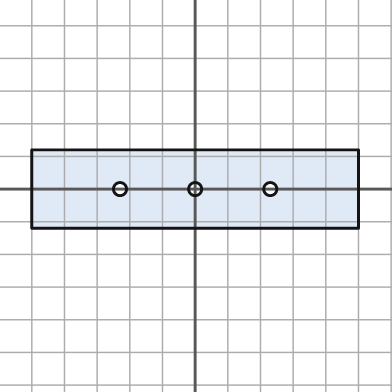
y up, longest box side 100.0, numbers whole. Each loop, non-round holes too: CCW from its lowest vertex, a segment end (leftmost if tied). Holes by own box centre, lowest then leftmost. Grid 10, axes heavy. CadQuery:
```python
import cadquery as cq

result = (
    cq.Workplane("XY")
    .moveTo(-50.0, -12.0)
    .lineTo(50.0, -12.0)
    .lineTo(50.0, 12.0)
    .lineTo(-50.0, 12.0)
    .close()
    .moveTo(-23.0, 0.0)
    .circle(2.0)
    .moveTo(0.0, 0.0)
    .circle(2.0)
    .moveTo(23.0, 0.0)
    .circle(2.0)
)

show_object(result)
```